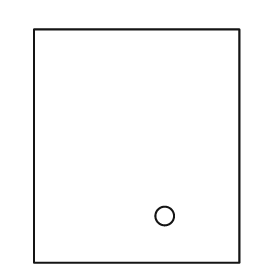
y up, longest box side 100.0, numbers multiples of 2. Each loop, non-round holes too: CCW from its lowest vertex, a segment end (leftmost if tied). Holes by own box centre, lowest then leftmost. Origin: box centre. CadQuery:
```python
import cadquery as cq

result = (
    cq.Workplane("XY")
    .moveTo(-44.0, -50.0)
    .lineTo(44.0, -50.0)
    .lineTo(44.0, 50.0)
    .lineTo(-44.0, 50.0)
    .close()
    .moveTo(12.0, -30.0)
    .circle(4.0)
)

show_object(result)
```